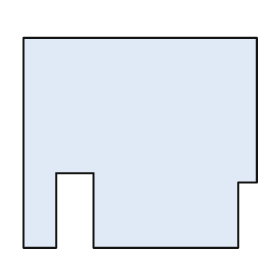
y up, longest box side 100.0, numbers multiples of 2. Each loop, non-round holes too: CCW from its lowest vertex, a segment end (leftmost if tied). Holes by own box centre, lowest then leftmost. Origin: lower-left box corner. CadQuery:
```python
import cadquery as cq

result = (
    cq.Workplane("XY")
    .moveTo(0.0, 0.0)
    .lineTo(14.0, 0.0)
    .lineTo(14.0, 32.0)
    .lineTo(30.0, 32.0)
    .lineTo(30.0, 0.0)
    .lineTo(92.0, 0.0)
    .lineTo(92.0, 28.0)
    .lineTo(100.0, 28.0)
    .lineTo(100.0, 90.0)
    .lineTo(0.0, 90.0)
    .close()
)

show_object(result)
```